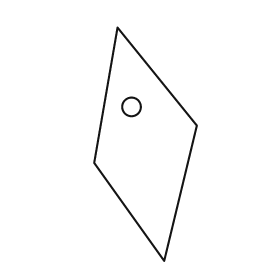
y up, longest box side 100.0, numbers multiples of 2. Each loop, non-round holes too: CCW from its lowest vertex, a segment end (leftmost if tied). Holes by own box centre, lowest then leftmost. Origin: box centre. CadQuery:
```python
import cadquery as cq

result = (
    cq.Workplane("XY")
    .moveTo(8.0, -50.0)
    .lineTo(22.0, 8.0)
    .lineTo(-12.0, 50.0)
    .lineTo(-22.0, -8.0)
    .close()
    .moveTo(-6.0, 16.0)
    .circle(4.0)
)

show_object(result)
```